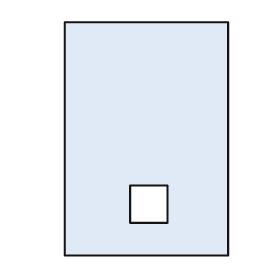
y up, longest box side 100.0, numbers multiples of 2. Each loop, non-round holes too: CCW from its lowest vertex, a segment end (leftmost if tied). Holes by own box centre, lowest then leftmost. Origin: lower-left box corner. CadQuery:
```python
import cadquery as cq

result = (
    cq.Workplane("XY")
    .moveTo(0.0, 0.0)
    .lineTo(70.0, 0.0)
    .lineTo(70.0, 100.0)
    .lineTo(0.0, 100.0)
    .close()
    .moveTo(28.0, 14.0)
    .lineTo(44.0, 14.0)
    .lineTo(44.0, 30.0)
    .lineTo(28.0, 30.0)
    .close()
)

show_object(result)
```